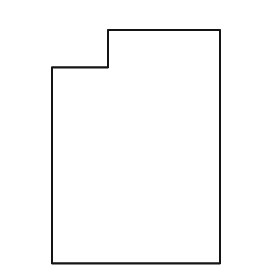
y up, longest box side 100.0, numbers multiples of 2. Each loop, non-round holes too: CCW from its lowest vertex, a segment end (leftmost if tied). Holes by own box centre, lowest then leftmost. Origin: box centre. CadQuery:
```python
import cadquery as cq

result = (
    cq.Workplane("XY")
    .moveTo(-36.0, -50.0)
    .lineTo(36.0, -50.0)
    .lineTo(36.0, 50.0)
    .lineTo(-12.0, 50.0)
    .lineTo(-12.0, 34.0)
    .lineTo(-36.0, 34.0)
    .close()
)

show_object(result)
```